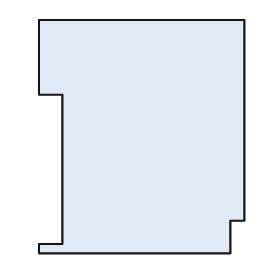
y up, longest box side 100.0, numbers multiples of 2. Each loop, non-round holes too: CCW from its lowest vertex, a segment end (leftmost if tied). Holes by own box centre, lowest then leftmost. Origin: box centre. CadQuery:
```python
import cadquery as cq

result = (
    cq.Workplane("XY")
    .moveTo(-44.0, -50.0)
    .lineTo(38.0, -50.0)
    .lineTo(38.0, -36.0)
    .lineTo(44.0, -36.0)
    .lineTo(44.0, 50.0)
    .lineTo(-44.0, 50.0)
    .lineTo(-44.0, 18.0)
    .lineTo(-34.0, 18.0)
    .lineTo(-34.0, -46.0)
    .lineTo(-44.0, -46.0)
    .close()
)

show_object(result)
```